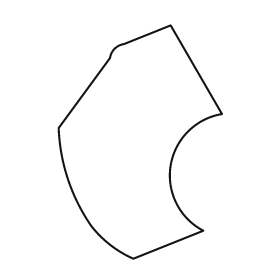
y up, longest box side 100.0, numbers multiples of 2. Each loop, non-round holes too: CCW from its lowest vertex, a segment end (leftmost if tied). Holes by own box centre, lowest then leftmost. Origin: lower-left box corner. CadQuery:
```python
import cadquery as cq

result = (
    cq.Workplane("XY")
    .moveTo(32.0, 0.0)
    .lineTo(62.0, 12.0)
    .threePointArc((48.0, 40.0), (70.0, 62.0))
    .lineTo(48.0, 100.0)
    .lineTo(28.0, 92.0)
    .threePointArc((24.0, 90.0), (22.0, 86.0))
    .lineTo(0.0, 56.0)
    .threePointArc((4.0, 34.0), (14.0, 14.0))
    .threePointArc((22.0, 6.0), (32.0, 0.0))
    .close()
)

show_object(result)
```